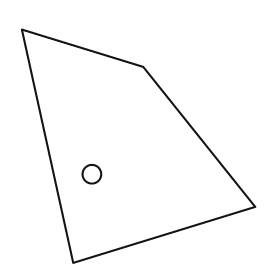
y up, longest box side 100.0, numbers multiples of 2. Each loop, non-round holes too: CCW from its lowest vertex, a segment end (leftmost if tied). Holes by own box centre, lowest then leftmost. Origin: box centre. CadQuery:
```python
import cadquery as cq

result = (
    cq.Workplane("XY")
    .moveTo(-28.0, -50.0)
    .lineTo(50.0, -26.0)
    .lineTo(2.0, 34.0)
    .lineTo(-50.0, 50.0)
    .close()
    .moveTo(-20.0, -12.0)
    .circle(4.0)
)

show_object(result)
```